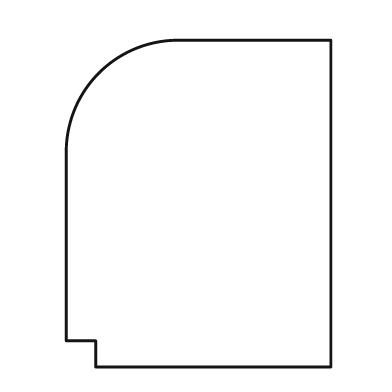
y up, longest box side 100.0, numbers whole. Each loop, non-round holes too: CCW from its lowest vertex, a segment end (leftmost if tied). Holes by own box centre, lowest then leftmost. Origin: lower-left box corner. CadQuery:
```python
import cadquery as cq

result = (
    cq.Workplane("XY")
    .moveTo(9.0, 0.0)
    .lineTo(81.0, 0.0)
    .lineTo(81.0, 100.0)
    .lineTo(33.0, 100.0)
    .threePointArc((10.0, 90.0), (0.0, 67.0))
    .lineTo(0.0, 8.0)
    .lineTo(9.0, 8.0)
    .close()
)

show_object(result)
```